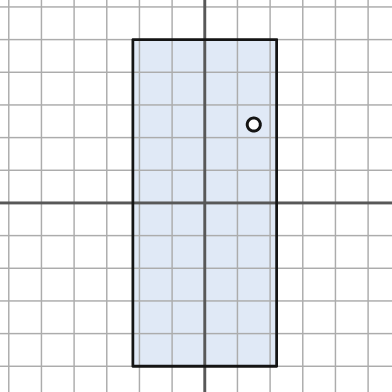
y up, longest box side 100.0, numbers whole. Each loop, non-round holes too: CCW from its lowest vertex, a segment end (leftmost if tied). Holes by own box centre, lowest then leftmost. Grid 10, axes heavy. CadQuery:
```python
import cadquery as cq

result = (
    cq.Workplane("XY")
    .moveTo(-22.0, -50.0)
    .lineTo(22.0, -50.0)
    .lineTo(22.0, 50.0)
    .lineTo(-22.0, 50.0)
    .close()
    .moveTo(15.0, 24.0)
    .circle(2.0)
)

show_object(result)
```